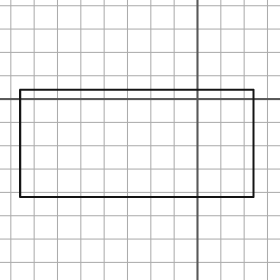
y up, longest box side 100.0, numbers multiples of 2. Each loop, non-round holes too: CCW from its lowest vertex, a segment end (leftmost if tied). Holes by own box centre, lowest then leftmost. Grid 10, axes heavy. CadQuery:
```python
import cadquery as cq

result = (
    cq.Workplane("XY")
    .moveTo(-76.0, -42.0)
    .lineTo(24.0, -42.0)
    .lineTo(24.0, 4.0)
    .lineTo(-76.0, 4.0)
    .close()
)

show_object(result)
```